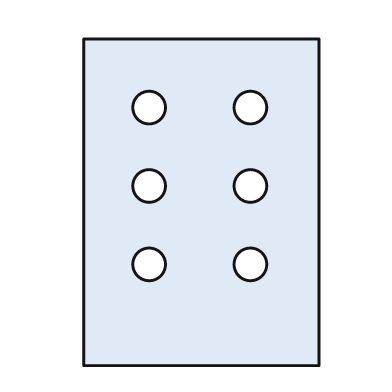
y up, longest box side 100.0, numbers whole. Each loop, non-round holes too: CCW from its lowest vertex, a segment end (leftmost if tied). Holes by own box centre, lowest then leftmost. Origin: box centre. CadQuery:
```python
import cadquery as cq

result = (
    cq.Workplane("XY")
    .moveTo(-36.0, -50.0)
    .lineTo(36.0, -50.0)
    .lineTo(36.0, 50.0)
    .lineTo(-36.0, 50.0)
    .close()
    .moveTo(-16.0, -19.0)
    .circle(5.0)
    .moveTo(15.0, -19.0)
    .circle(5.0)
    .moveTo(-16.0, 5.0)
    .circle(5.0)
    .moveTo(15.0, 5.0)
    .circle(5.0)
    .moveTo(-16.0, 29.0)
    .circle(5.0)
    .moveTo(15.0, 29.0)
    .circle(5.0)
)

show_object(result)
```